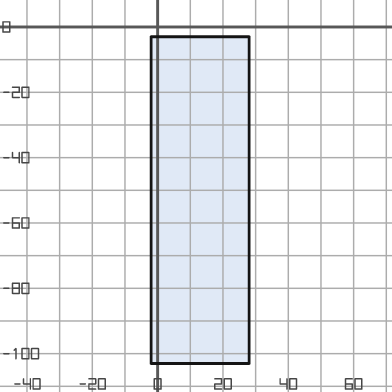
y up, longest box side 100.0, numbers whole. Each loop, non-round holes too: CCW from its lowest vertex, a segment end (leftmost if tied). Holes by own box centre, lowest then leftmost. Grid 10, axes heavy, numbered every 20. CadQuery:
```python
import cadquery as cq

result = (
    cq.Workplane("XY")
    .moveTo(-2.0, -103.0)
    .lineTo(28.0, -103.0)
    .lineTo(28.0, -3.0)
    .lineTo(-2.0, -3.0)
    .close()
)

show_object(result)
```